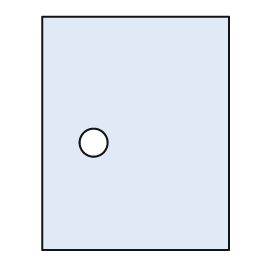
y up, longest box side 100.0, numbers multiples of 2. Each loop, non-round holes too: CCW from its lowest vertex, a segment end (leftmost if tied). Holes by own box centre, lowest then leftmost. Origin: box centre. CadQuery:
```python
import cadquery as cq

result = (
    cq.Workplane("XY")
    .moveTo(-40.0, -50.0)
    .lineTo(40.0, -50.0)
    .lineTo(40.0, 50.0)
    .lineTo(-40.0, 50.0)
    .close()
    .moveTo(-18.0, -4.0)
    .circle(6.0)
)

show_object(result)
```